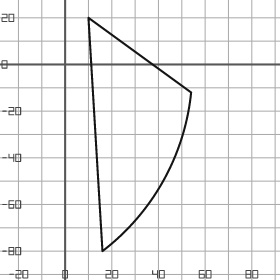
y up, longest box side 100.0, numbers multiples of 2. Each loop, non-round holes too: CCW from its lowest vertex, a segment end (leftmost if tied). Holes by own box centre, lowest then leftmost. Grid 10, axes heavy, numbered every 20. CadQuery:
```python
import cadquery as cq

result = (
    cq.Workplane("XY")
    .moveTo(16.0, -80.0)
    .threePointArc((42.0, -50.0), (54.0, -12.0))
    .lineTo(10.0, 20.0)
    .close()
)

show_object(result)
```